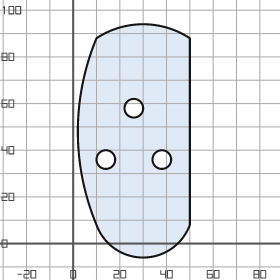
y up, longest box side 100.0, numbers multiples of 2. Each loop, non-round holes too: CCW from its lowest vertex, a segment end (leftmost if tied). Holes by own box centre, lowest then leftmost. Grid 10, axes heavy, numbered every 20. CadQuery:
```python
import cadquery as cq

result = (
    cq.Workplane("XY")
    .moveTo(10.0, 8.0)
    .threePointArc((30.0, -6.0), (50.0, 8.0))
    .lineTo(50.0, 88.0)
    .threePointArc((30.0, 94.0), (10.0, 88.0))
    .threePointArc((2.0, 48.0), (10.0, 8.0))
    .close()
    .moveTo(14.0, 36.0)
    .circle(4.0)
    .moveTo(38.0, 36.0)
    .circle(4.0)
    .moveTo(26.0, 58.0)
    .circle(4.0)
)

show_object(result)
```